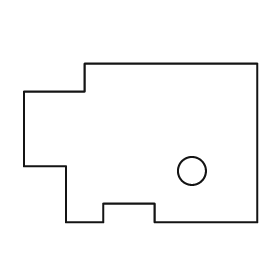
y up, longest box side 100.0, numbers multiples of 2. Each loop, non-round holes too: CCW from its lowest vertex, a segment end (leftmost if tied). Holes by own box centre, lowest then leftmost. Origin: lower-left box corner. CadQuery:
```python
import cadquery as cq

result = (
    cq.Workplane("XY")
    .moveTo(18.0, 0.0)
    .lineTo(34.0, 0.0)
    .lineTo(34.0, 8.0)
    .lineTo(56.0, 8.0)
    .lineTo(56.0, 0.0)
    .lineTo(100.0, 0.0)
    .lineTo(100.0, 68.0)
    .lineTo(26.0, 68.0)
    .lineTo(26.0, 56.0)
    .lineTo(0.0, 56.0)
    .lineTo(0.0, 24.0)
    .lineTo(18.0, 24.0)
    .close()
    .moveTo(72.0, 22.0)
    .circle(6.0)
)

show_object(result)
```